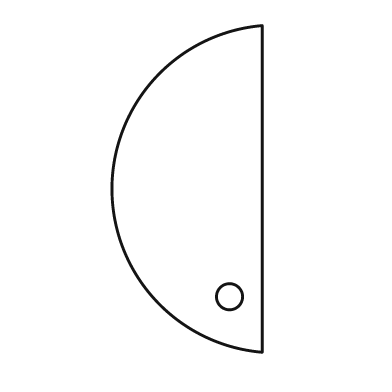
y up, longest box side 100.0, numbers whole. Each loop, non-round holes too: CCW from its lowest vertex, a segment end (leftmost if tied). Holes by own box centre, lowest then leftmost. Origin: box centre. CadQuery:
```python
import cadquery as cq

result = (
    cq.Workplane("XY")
    .moveTo(23.0, -50.0)
    .lineTo(23.0, 50.0)
    .threePointArc((-23.0, 0.0), (23.0, -50.0))
    .close()
    .moveTo(13.0, -33.0)
    .circle(4.0)
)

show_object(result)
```